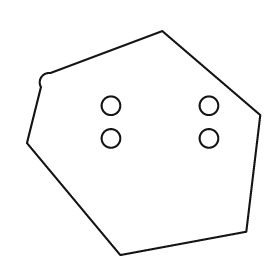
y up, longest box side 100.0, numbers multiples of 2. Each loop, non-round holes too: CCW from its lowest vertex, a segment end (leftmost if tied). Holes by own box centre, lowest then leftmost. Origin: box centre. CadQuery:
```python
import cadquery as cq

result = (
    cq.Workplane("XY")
    .moveTo(-10.0, -48.0)
    .lineTo(44.0, -38.0)
    .lineTo(50.0, 12.0)
    .lineTo(8.0, 48.0)
    .lineTo(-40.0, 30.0)
    .threePointArc((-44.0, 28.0), (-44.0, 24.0))
    .lineTo(-50.0, 0.0)
    .close()
    .moveTo(-14.0, 2.0)
    .circle(4.0)
    .moveTo(28.0, 2.0)
    .circle(4.0)
    .moveTo(-14.0, 16.0)
    .circle(4.0)
    .moveTo(28.0, 16.0)
    .circle(4.0)
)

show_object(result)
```